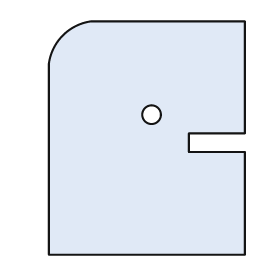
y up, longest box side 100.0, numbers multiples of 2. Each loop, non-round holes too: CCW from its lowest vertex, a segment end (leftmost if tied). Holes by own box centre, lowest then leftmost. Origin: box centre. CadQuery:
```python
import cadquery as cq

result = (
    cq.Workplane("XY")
    .moveTo(-42.0, -50.0)
    .lineTo(42.0, -50.0)
    .lineTo(42.0, -6.0)
    .lineTo(18.0, -6.0)
    .lineTo(18.0, 2.0)
    .lineTo(42.0, 2.0)
    .lineTo(42.0, 50.0)
    .lineTo(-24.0, 50.0)
    .threePointArc((-36.0, 44.0), (-42.0, 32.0))
    .close()
    .moveTo(2.0, 10.0)
    .circle(4.0)
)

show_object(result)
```